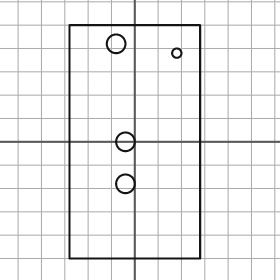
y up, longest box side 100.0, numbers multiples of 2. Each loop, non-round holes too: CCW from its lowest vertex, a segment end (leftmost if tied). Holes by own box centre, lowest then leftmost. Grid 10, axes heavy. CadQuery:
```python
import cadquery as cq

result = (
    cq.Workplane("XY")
    .moveTo(-28.0, -50.0)
    .lineTo(28.0, -50.0)
    .lineTo(28.0, 50.0)
    .lineTo(-28.0, 50.0)
    .close()
    .moveTo(-4.0, -18.0)
    .circle(4.0)
    .moveTo(-4.0, 0.0)
    .circle(4.0)
    .moveTo(18.0, 38.0)
    .circle(2.0)
    .moveTo(-8.0, 42.0)
    .circle(4.0)
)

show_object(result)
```